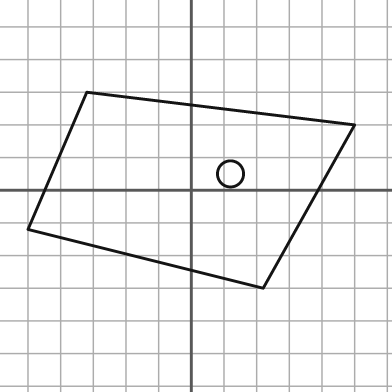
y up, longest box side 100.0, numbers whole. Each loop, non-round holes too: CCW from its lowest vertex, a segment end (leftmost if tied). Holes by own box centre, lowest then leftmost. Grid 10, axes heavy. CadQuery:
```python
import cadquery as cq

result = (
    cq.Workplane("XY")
    .moveTo(22.0, -30.0)
    .lineTo(50.0, 20.0)
    .lineTo(-32.0, 30.0)
    .lineTo(-50.0, -12.0)
    .close()
    .moveTo(12.0, 5.0)
    .circle(4.0)
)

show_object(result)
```